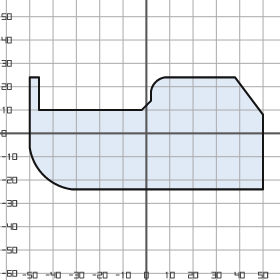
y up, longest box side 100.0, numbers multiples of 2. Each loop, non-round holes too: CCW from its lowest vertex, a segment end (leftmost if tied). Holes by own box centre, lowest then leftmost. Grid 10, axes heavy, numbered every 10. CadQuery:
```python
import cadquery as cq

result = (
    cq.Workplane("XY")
    .moveTo(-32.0, -24.0)
    .lineTo(50.0, -24.0)
    .lineTo(50.0, 8.0)
    .lineTo(38.0, 24.0)
    .lineTo(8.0, 24.0)
    .threePointArc((4.0, 22.0), (2.0, 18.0))
    .lineTo(2.0, 14.0)
    .lineTo(-2.0, 10.0)
    .lineTo(-46.0, 10.0)
    .lineTo(-46.0, 24.0)
    .lineTo(-50.0, 24.0)
    .lineTo(-50.0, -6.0)
    .threePointArc((-44.0, -18.0), (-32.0, -24.0))
    .close()
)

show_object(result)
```